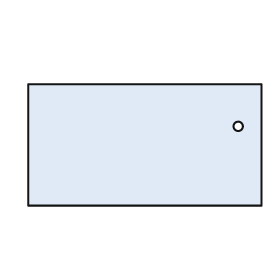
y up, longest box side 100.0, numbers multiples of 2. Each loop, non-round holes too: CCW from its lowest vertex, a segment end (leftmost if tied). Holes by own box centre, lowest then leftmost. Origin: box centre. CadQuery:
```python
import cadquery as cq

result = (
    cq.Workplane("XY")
    .moveTo(-50.0, -26.0)
    .lineTo(50.0, -26.0)
    .lineTo(50.0, 26.0)
    .lineTo(-50.0, 26.0)
    .close()
    .moveTo(40.0, 8.0)
    .circle(2.0)
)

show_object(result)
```